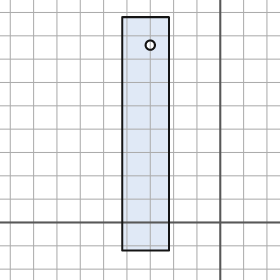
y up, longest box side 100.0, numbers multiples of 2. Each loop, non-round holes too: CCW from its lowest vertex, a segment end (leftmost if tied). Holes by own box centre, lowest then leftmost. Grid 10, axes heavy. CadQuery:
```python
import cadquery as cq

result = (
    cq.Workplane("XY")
    .moveTo(-42.0, -12.0)
    .lineTo(-22.0, -12.0)
    .lineTo(-22.0, 88.0)
    .lineTo(-42.0, 88.0)
    .close()
    .moveTo(-30.0, 76.0)
    .circle(2.0)
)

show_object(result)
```